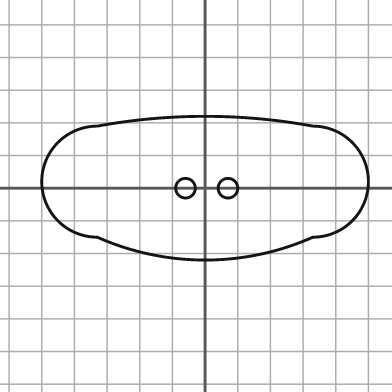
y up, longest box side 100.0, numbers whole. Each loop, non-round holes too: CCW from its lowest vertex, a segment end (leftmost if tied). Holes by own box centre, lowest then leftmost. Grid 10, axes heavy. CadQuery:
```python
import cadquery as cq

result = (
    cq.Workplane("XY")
    .moveTo(-33.0, -15.0)
    .threePointArc((0.0, -22.0), (33.0, -15.0))
    .threePointArc((50.0, 2.0), (33.0, 19.0))
    .threePointArc((0.0, 22.0), (-33.0, 19.0))
    .threePointArc((-50.0, 2.0), (-33.0, -15.0))
    .close()
    .moveTo(-6.0, 0.0)
    .circle(3.0)
    .moveTo(7.0, 0.0)
    .circle(3.0)
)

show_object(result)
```